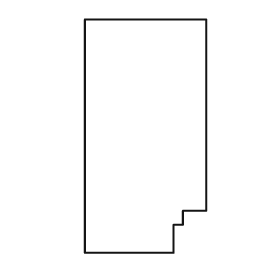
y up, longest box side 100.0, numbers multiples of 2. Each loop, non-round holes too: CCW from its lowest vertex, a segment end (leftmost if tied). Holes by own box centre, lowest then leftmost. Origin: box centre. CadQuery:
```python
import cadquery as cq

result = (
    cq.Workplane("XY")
    .moveTo(-26.0, -50.0)
    .lineTo(12.0, -50.0)
    .lineTo(12.0, -38.0)
    .lineTo(16.0, -38.0)
    .lineTo(16.0, -32.0)
    .lineTo(26.0, -32.0)
    .lineTo(26.0, 50.0)
    .lineTo(-26.0, 50.0)
    .close()
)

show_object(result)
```